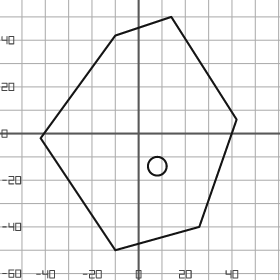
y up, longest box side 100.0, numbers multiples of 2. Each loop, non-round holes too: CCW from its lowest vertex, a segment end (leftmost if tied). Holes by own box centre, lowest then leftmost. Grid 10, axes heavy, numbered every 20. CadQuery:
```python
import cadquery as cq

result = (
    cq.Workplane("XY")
    .moveTo(-10.0, -50.0)
    .lineTo(26.0, -40.0)
    .lineTo(42.0, 6.0)
    .lineTo(14.0, 50.0)
    .lineTo(-10.0, 42.0)
    .lineTo(-42.0, -2.0)
    .close()
    .moveTo(8.0, -14.0)
    .circle(4.0)
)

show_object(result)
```